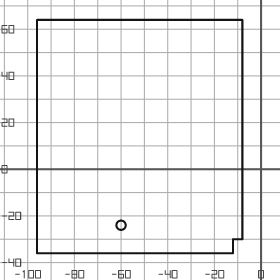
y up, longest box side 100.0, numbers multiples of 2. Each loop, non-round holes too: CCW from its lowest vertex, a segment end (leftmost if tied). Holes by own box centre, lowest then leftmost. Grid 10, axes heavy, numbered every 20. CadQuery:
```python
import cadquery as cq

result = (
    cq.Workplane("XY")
    .moveTo(-96.0, -36.0)
    .lineTo(-12.0, -36.0)
    .lineTo(-12.0, -30.0)
    .lineTo(-8.0, -30.0)
    .lineTo(-8.0, 64.0)
    .lineTo(-96.0, 64.0)
    .close()
    .moveTo(-60.0, -24.0)
    .circle(2.0)
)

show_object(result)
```